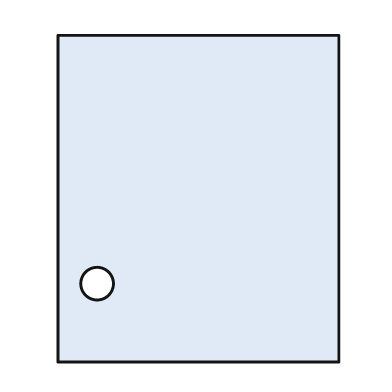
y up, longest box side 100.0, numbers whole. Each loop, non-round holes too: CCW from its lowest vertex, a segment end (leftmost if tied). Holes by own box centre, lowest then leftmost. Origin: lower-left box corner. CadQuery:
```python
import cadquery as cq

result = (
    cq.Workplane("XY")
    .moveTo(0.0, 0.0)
    .lineTo(86.0, 0.0)
    .lineTo(86.0, 100.0)
    .lineTo(0.0, 100.0)
    .close()
    .moveTo(12.0, 24.0)
    .circle(5.0)
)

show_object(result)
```